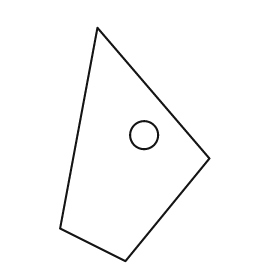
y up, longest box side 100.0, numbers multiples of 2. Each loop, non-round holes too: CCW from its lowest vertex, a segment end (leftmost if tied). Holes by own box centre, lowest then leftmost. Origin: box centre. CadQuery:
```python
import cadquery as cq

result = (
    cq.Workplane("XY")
    .moveTo(-4.0, -50.0)
    .lineTo(32.0, -6.0)
    .lineTo(-16.0, 50.0)
    .lineTo(-32.0, -36.0)
    .close()
    .moveTo(4.0, 4.0)
    .circle(6.0)
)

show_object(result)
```